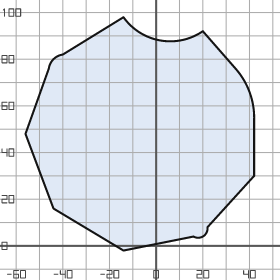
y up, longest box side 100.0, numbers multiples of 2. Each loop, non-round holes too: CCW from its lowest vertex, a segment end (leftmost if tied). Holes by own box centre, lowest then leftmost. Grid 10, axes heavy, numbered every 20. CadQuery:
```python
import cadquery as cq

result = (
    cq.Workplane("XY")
    .moveTo(-14.0, -2.0)
    .lineTo(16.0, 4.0)
    .threePointArc((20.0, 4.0), (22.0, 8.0))
    .lineTo(42.0, 30.0)
    .lineTo(42.0, 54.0)
    .threePointArc((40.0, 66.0), (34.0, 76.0))
    .lineTo(20.0, 92.0)
    .threePointArc((2.0, 88.0), (-14.0, 98.0))
    .lineTo(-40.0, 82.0)
    .threePointArc((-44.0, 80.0), (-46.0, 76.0))
    .lineTo(-56.0, 48.0)
    .lineTo(-44.0, 16.0)
    .close()
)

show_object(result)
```